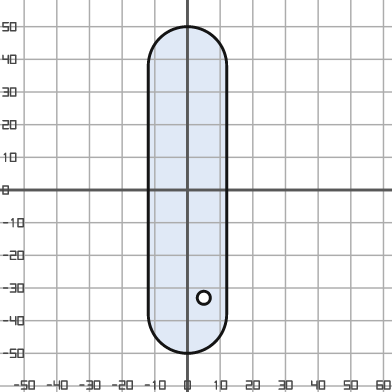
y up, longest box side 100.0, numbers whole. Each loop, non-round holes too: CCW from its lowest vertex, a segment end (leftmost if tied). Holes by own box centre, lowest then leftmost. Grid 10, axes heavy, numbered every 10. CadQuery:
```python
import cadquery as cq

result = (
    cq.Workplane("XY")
    .moveTo(-12.0, -38.0)
    .threePointArc((0.0, -50.0), (12.0, -38.0))
    .lineTo(12.0, 38.0)
    .threePointArc((0.0, 50.0), (-12.0, 38.0))
    .close()
    .moveTo(5.0, -33.0)
    .circle(2.0)
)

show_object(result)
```